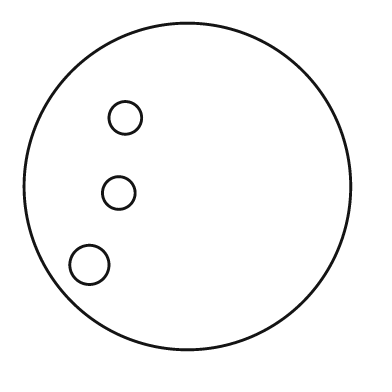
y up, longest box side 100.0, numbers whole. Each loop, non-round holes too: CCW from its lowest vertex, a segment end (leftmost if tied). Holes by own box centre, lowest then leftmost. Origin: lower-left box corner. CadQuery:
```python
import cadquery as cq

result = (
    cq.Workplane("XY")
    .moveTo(50.0, 50.0)
    .circle(50.0)
    .moveTo(20.0, 26.0)
    .circle(6.0)
    .moveTo(29.0, 48.0)
    .circle(5.0)
    .moveTo(31.0, 71.0)
    .circle(5.0)
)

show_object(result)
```